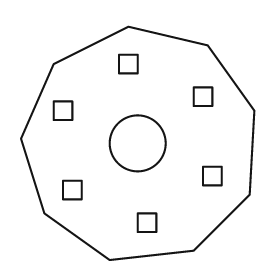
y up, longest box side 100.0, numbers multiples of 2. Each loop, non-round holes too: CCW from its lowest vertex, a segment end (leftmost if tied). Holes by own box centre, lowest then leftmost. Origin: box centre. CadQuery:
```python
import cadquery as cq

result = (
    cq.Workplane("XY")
    .moveTo(-12.0, -50.0)
    .lineTo(24.0, -46.0)
    .lineTo(48.0, -22.0)
    .lineTo(50.0, 14.0)
    .lineTo(30.0, 42.0)
    .lineTo(-4.0, 50.0)
    .lineTo(-36.0, 34.0)
    .lineTo(-50.0, 2.0)
    .lineTo(-40.0, -30.0)
    .close()
    .moveTo(0.0, -38.0)
    .lineTo(8.0, -38.0)
    .lineTo(8.0, -30.0)
    .lineTo(0.0, -30.0)
    .close()
    .moveTo(-32.0, -24.0)
    .lineTo(-24.0, -24.0)
    .lineTo(-24.0, -16.0)
    .lineTo(-32.0, -16.0)
    .close()
    .moveTo(28.0, -18.0)
    .lineTo(36.0, -18.0)
    .lineTo(36.0, -10.0)
    .lineTo(28.0, -10.0)
    .close()
    .moveTo(0.0, 0.0)
    .circle(12.0)
    .moveTo(-36.0, 10.0)
    .lineTo(-28.0, 10.0)
    .lineTo(-28.0, 18.0)
    .lineTo(-36.0, 18.0)
    .close()
    .moveTo(24.0, 16.0)
    .lineTo(32.0, 16.0)
    .lineTo(32.0, 24.0)
    .lineTo(24.0, 24.0)
    .close()
    .moveTo(-8.0, 30.0)
    .lineTo(0.0, 30.0)
    .lineTo(0.0, 38.0)
    .lineTo(-8.0, 38.0)
    .close()
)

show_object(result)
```